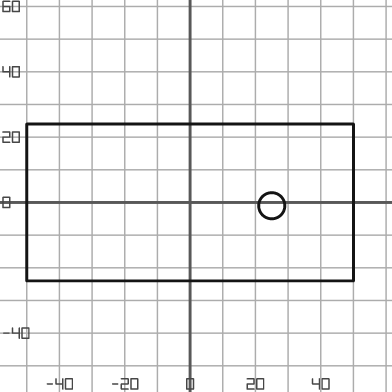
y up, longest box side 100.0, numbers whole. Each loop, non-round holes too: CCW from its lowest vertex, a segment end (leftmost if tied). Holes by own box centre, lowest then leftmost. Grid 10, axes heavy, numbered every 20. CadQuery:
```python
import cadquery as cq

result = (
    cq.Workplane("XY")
    .moveTo(-50.0, -24.0)
    .lineTo(50.0, -24.0)
    .lineTo(50.0, 24.0)
    .lineTo(-50.0, 24.0)
    .close()
    .moveTo(25.0, -1.0)
    .circle(4.0)
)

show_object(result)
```